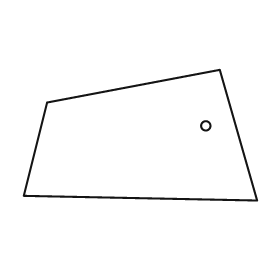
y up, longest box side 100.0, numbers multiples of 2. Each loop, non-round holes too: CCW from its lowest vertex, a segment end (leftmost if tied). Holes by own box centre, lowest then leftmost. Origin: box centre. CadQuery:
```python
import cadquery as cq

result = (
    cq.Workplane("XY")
    .moveTo(50.0, -28.0)
    .lineTo(34.0, 28.0)
    .lineTo(-40.0, 14.0)
    .lineTo(-50.0, -26.0)
    .close()
    .moveTo(28.0, 4.0)
    .circle(2.0)
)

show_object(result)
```